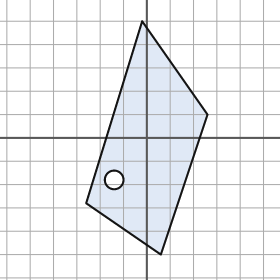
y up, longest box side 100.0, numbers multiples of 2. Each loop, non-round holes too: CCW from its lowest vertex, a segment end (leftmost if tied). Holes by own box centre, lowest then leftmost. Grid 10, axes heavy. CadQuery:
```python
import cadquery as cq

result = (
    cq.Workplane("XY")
    .moveTo(6.0, -50.0)
    .lineTo(26.0, 10.0)
    .lineTo(-2.0, 50.0)
    .lineTo(-26.0, -28.0)
    .close()
    .moveTo(-14.0, -18.0)
    .circle(4.0)
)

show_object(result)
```